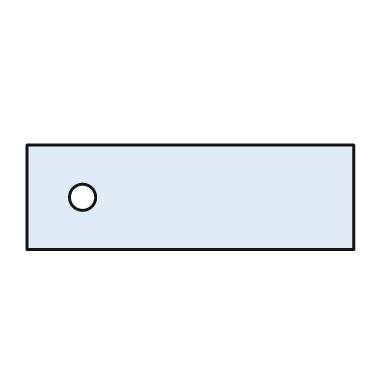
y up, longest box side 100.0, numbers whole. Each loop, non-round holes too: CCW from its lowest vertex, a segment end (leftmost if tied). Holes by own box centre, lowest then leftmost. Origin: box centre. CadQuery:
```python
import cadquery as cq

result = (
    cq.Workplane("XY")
    .moveTo(-50.0, -16.0)
    .lineTo(50.0, -16.0)
    .lineTo(50.0, 16.0)
    .lineTo(-50.0, 16.0)
    .close()
    .moveTo(-33.0, 0.0)
    .circle(4.0)
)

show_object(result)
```